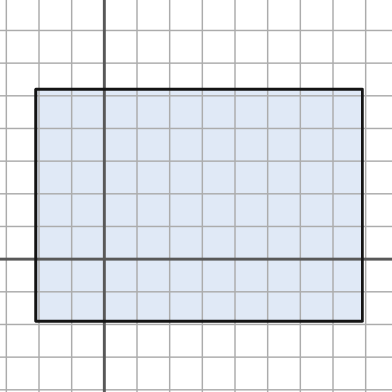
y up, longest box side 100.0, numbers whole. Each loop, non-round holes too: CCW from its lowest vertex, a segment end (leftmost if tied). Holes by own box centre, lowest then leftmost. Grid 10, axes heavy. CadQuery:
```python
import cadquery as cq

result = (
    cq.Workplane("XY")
    .moveTo(-21.0, -19.0)
    .lineTo(79.0, -19.0)
    .lineTo(79.0, 52.0)
    .lineTo(-21.0, 52.0)
    .close()
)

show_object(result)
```